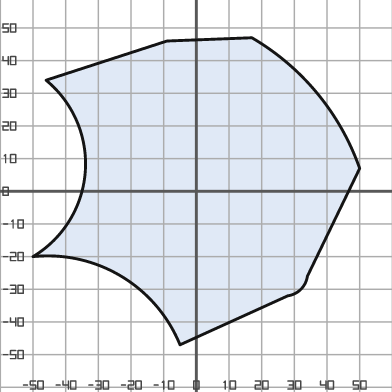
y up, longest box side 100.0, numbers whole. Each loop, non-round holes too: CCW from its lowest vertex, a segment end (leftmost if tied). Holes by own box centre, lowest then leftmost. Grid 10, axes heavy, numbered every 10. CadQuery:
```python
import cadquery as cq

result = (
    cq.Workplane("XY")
    .moveTo(-5.0, -47.0)
    .lineTo(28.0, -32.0)
    .threePointArc((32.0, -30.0), (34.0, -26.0))
    .lineTo(50.0, 7.0)
    .threePointArc((37.0, 30.0), (17.0, 47.0))
    .lineTo(-9.0, 46.0)
    .lineTo(-46.0, 34.0)
    .threePointArc((-34.0, 6.0), (-50.0, -20.0))
    .threePointArc((-23.0, -26.0), (-5.0, -47.0))
    .close()
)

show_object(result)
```